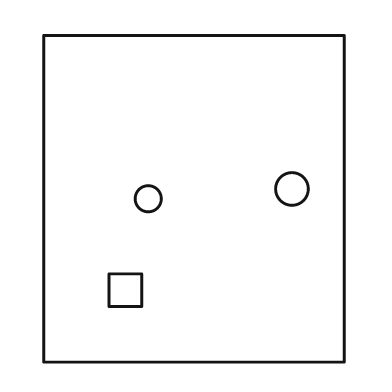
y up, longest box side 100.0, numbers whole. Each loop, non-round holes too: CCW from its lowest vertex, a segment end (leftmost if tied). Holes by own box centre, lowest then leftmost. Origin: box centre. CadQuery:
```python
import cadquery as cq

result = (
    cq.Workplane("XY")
    .moveTo(-46.0, -50.0)
    .lineTo(46.0, -50.0)
    .lineTo(46.0, 50.0)
    .lineTo(-46.0, 50.0)
    .close()
    .moveTo(-26.0, -33.0)
    .lineTo(-16.0, -33.0)
    .lineTo(-16.0, -23.0)
    .lineTo(-26.0, -23.0)
    .close()
    .moveTo(-14.0, 0.0)
    .circle(4.0)
    .moveTo(30.0, 3.0)
    .circle(5.0)
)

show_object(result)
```